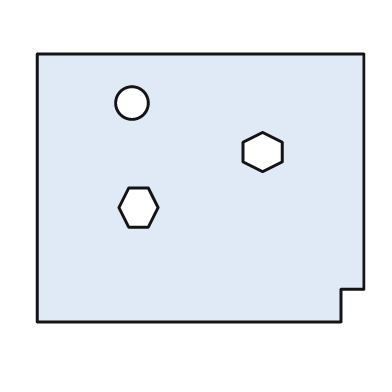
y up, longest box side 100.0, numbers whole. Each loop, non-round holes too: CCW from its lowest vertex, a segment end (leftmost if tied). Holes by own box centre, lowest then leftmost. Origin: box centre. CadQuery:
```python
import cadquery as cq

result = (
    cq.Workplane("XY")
    .moveTo(-50.0, -41.0)
    .lineTo(43.0, -41.0)
    .lineTo(43.0, -31.0)
    .lineTo(50.0, -31.0)
    .lineTo(50.0, 41.0)
    .lineTo(-50.0, 41.0)
    .close()
    .moveTo(-22.0, -12.0)
    .lineTo(-16.0, -12.0)
    .lineTo(-13.0, -6.0)
    .lineTo(-16.0, 0.0)
    .lineTo(-22.0, 0.0)
    .lineTo(-25.0, -6.0)
    .close()
    .moveTo(19.0, 5.0)
    .lineTo(25.0, 8.0)
    .lineTo(25.0, 14.0)
    .lineTo(19.0, 17.0)
    .lineTo(13.0, 14.0)
    .lineTo(13.0, 8.0)
    .close()
    .moveTo(-21.0, 26.0)
    .circle(5.0)
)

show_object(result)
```